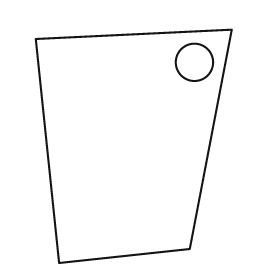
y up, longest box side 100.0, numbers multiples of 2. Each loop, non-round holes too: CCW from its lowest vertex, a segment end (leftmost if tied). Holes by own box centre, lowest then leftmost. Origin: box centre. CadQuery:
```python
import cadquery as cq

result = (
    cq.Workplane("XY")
    .moveTo(-32.0, -50.0)
    .lineTo(24.0, -44.0)
    .lineTo(42.0, 50.0)
    .lineTo(-42.0, 46.0)
    .close()
    .moveTo(26.0, 36.0)
    .circle(8.0)
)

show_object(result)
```